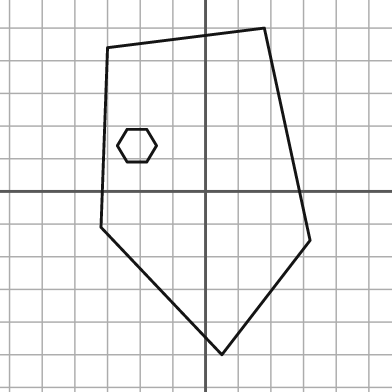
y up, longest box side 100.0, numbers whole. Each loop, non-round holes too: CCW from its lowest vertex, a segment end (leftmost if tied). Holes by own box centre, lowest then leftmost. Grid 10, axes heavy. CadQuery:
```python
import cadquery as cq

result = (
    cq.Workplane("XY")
    .moveTo(5.0, -50.0)
    .lineTo(32.0, -15.0)
    .lineTo(18.0, 50.0)
    .lineTo(-30.0, 44.0)
    .lineTo(-32.0, -11.0)
    .close()
    .moveTo(-24.0, 9.0)
    .lineTo(-18.0, 9.0)
    .lineTo(-15.0, 14.0)
    .lineTo(-18.0, 19.0)
    .lineTo(-24.0, 19.0)
    .lineTo(-27.0, 14.0)
    .close()
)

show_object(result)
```